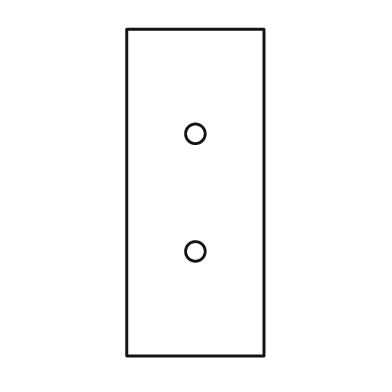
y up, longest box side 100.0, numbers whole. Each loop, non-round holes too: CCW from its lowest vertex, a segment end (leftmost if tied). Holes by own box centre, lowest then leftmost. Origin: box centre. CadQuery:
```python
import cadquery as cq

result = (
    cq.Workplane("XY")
    .moveTo(-21.0, -50.0)
    .lineTo(21.0, -50.0)
    .lineTo(21.0, 50.0)
    .lineTo(-21.0, 50.0)
    .close()
    .moveTo(0.0, -18.0)
    .circle(3.0)
    .moveTo(0.0, 18.0)
    .circle(3.0)
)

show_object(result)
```